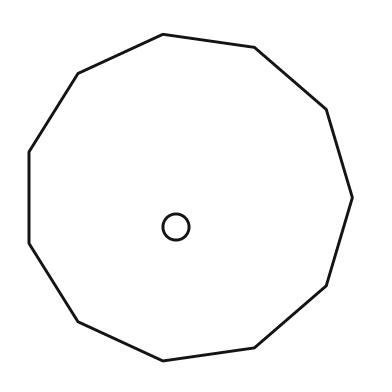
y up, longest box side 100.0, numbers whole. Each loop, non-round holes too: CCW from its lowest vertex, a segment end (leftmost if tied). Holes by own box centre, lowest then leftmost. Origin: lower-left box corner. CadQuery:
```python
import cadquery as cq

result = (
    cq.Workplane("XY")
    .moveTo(41.0, 0.0)
    .lineTo(69.0, 4.0)
    .lineTo(91.0, 23.0)
    .lineTo(99.0, 50.0)
    .lineTo(91.0, 77.0)
    .lineTo(69.0, 96.0)
    .lineTo(41.0, 100.0)
    .lineTo(15.0, 88.0)
    .lineTo(0.0, 64.0)
    .lineTo(0.0, 36.0)
    .lineTo(15.0, 12.0)
    .close()
    .moveTo(45.0, 41.0)
    .circle(4.0)
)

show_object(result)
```